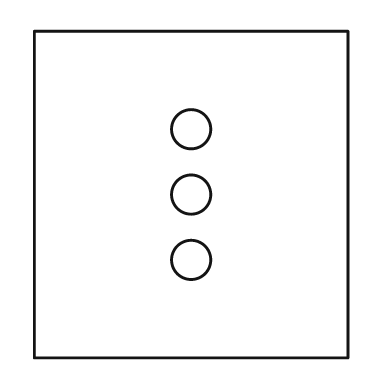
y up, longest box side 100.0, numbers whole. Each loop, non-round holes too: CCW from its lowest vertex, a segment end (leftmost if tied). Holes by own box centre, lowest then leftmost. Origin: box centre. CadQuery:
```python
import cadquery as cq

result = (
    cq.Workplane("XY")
    .moveTo(-48.0, -50.0)
    .lineTo(48.0, -50.0)
    .lineTo(48.0, 50.0)
    .lineTo(-48.0, 50.0)
    .close()
    .moveTo(0.0, -20.0)
    .circle(6.0)
    .moveTo(0.0, 0.0)
    .circle(6.0)
    .moveTo(0.0, 20.0)
    .circle(6.0)
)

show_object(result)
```